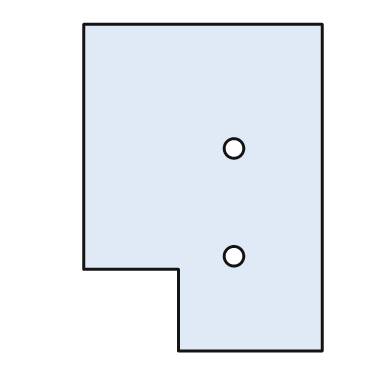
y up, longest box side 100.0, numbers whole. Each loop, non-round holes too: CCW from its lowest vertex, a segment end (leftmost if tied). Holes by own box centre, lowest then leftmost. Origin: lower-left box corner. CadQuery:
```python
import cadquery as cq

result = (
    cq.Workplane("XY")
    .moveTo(29.0, 0.0)
    .lineTo(73.0, 0.0)
    .lineTo(73.0, 100.0)
    .lineTo(0.0, 100.0)
    .lineTo(0.0, 25.0)
    .lineTo(29.0, 25.0)
    .close()
    .moveTo(46.0, 29.0)
    .circle(3.0)
    .moveTo(46.0, 62.0)
    .circle(3.0)
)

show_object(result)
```